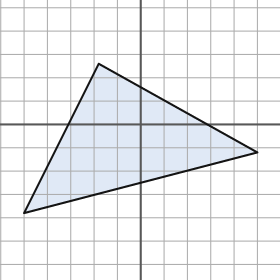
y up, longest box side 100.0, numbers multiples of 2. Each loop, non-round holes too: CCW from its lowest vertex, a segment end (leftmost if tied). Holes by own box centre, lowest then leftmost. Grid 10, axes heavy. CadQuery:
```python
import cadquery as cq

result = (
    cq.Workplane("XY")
    .moveTo(-50.0, -38.0)
    .lineTo(50.0, -12.0)
    .lineTo(-18.0, 26.0)
    .close()
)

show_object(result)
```